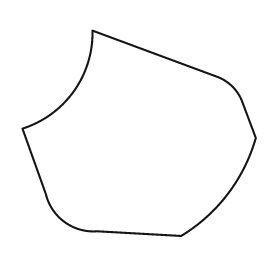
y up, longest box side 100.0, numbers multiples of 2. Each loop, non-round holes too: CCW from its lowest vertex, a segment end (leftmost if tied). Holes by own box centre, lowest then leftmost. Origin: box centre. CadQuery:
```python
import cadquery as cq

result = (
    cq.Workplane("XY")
    .moveTo(18.0, -44.0)
    .threePointArc((38.0, -26.0), (50.0, -2.0))
    .lineTo(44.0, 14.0)
    .threePointArc((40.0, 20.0), (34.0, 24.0))
    .lineTo(-20.0, 44.0)
    .threePointArc((-28.0, 18.0), (-50.0, 2.0))
    .lineTo(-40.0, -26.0)
    .threePointArc((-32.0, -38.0), (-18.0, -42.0))
    .close()
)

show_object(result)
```